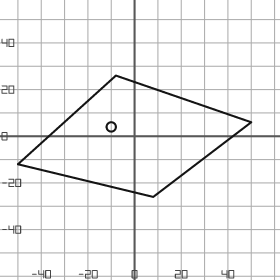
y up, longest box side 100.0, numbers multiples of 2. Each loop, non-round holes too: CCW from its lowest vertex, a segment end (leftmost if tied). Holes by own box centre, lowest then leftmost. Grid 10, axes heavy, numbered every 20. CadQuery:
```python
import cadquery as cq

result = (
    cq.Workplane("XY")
    .moveTo(8.0, -26.0)
    .lineTo(50.0, 6.0)
    .lineTo(-8.0, 26.0)
    .lineTo(-50.0, -12.0)
    .close()
    .moveTo(-10.0, 4.0)
    .circle(2.0)
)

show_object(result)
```